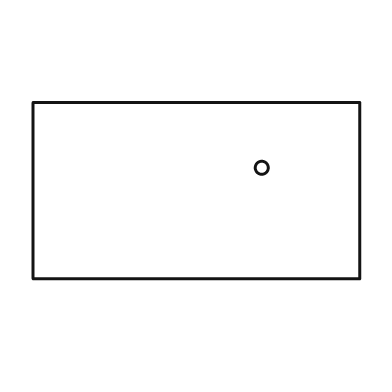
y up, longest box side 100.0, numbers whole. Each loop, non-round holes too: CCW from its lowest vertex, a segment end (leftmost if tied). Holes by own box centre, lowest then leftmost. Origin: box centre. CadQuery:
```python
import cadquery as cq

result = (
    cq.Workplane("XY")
    .moveTo(-50.0, -27.0)
    .lineTo(50.0, -27.0)
    .lineTo(50.0, 27.0)
    .lineTo(-50.0, 27.0)
    .close()
    .moveTo(20.0, 7.0)
    .circle(2.0)
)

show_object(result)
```